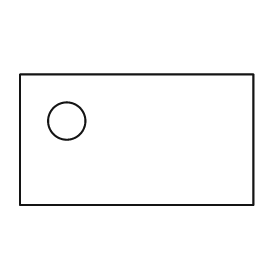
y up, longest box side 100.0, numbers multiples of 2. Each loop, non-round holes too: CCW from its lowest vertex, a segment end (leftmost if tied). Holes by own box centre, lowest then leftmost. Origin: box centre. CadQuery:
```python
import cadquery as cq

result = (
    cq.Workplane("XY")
    .moveTo(-50.0, -28.0)
    .lineTo(50.0, -28.0)
    .lineTo(50.0, 28.0)
    .lineTo(-50.0, 28.0)
    .close()
    .moveTo(-30.0, 8.0)
    .circle(8.0)
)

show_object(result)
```